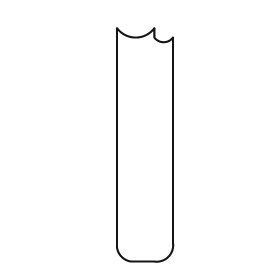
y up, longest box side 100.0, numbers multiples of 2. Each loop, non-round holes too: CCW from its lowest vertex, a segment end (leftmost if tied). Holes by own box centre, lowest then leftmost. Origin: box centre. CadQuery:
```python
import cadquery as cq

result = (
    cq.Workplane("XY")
    .moveTo(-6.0, -50.0)
    .lineTo(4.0, -50.0)
    .threePointArc((10.0, -48.0), (12.0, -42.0))
    .lineTo(12.0, 46.0)
    .threePointArc((8.0, 44.0), (4.0, 46.0))
    .lineTo(4.0, 50.0)
    .threePointArc((-4.0, 46.0), (-12.0, 50.0))
    .lineTo(-12.0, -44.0)
    .threePointArc((-10.0, -48.0), (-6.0, -50.0))
    .close()
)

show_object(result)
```